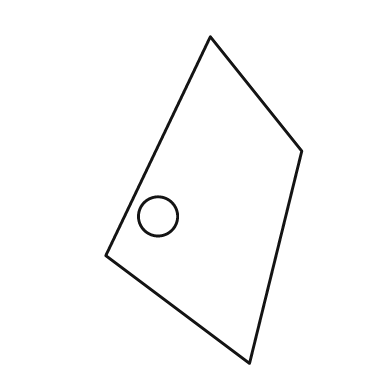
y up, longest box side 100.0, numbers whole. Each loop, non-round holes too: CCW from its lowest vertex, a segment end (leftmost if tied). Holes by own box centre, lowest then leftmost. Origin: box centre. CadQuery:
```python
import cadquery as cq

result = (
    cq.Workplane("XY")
    .moveTo(14.0, -50.0)
    .lineTo(30.0, 15.0)
    .lineTo(2.0, 50.0)
    .lineTo(-30.0, -17.0)
    .close()
    .moveTo(-14.0, -5.0)
    .circle(6.0)
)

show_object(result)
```